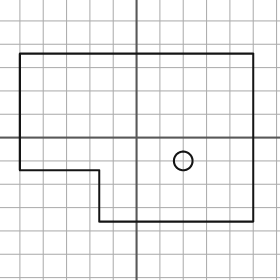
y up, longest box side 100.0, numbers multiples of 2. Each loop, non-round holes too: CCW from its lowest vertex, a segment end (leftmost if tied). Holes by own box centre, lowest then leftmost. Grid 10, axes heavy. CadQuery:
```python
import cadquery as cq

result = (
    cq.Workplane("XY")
    .moveTo(-16.0, -36.0)
    .lineTo(50.0, -36.0)
    .lineTo(50.0, 36.0)
    .lineTo(-50.0, 36.0)
    .lineTo(-50.0, -14.0)
    .lineTo(-16.0, -14.0)
    .close()
    .moveTo(20.0, -10.0)
    .circle(4.0)
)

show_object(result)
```